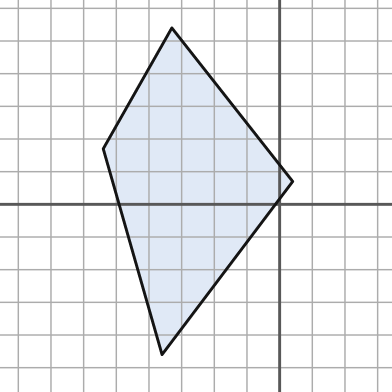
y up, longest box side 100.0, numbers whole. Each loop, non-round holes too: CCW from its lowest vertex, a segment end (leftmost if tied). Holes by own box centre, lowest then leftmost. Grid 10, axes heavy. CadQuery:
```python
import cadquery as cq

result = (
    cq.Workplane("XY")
    .moveTo(-36.0, -46.0)
    .lineTo(4.0, 7.0)
    .lineTo(-33.0, 54.0)
    .lineTo(-54.0, 17.0)
    .close()
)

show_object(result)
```